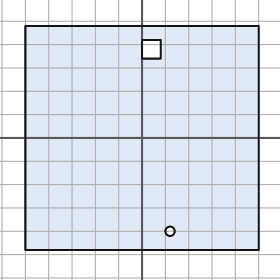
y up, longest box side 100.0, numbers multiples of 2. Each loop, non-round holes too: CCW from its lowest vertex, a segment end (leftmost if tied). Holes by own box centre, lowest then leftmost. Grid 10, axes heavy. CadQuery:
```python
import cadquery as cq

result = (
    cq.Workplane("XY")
    .moveTo(-50.0, -48.0)
    .lineTo(50.0, -48.0)
    .lineTo(50.0, 48.0)
    .lineTo(-50.0, 48.0)
    .close()
    .moveTo(12.0, -40.0)
    .circle(2.0)
    .moveTo(0.0, 34.0)
    .lineTo(8.0, 34.0)
    .lineTo(8.0, 42.0)
    .lineTo(0.0, 42.0)
    .close()
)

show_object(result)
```